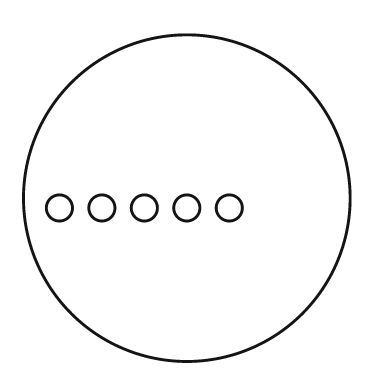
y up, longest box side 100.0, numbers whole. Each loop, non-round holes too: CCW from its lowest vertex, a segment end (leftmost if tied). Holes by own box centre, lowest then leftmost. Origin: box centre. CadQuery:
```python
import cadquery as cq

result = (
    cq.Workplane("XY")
    .moveTo(0.0, 0.0)
    .circle(50.0)
    .moveTo(-39.0, -3.0)
    .circle(4.0)
    .moveTo(-26.0, -3.0)
    .circle(4.0)
    .moveTo(-13.0, -3.0)
    .circle(4.0)
    .moveTo(0.0, -3.0)
    .circle(4.0)
    .moveTo(13.0, -3.0)
    .circle(4.0)
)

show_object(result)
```